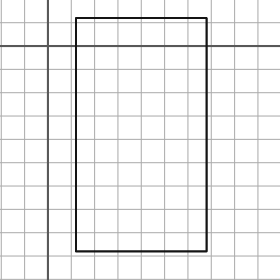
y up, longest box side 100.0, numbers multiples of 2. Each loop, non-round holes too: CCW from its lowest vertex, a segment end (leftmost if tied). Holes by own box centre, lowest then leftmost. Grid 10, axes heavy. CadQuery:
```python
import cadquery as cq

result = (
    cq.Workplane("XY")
    .moveTo(12.0, -88.0)
    .lineTo(68.0, -88.0)
    .lineTo(68.0, 12.0)
    .lineTo(12.0, 12.0)
    .close()
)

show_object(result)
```